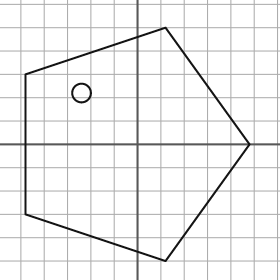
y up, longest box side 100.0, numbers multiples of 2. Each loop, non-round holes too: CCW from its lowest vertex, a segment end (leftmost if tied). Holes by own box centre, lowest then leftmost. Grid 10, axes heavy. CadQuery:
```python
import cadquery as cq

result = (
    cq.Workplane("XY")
    .moveTo(12.0, -50.0)
    .lineTo(48.0, 0.0)
    .lineTo(12.0, 50.0)
    .lineTo(-48.0, 30.0)
    .lineTo(-48.0, -30.0)
    .close()
    .moveTo(-24.0, 22.0)
    .circle(4.0)
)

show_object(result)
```